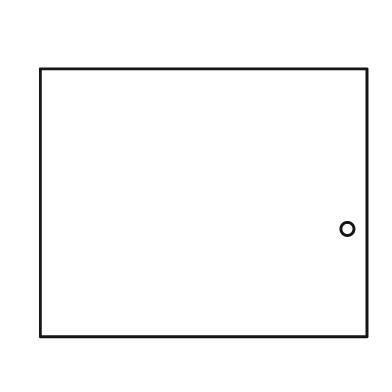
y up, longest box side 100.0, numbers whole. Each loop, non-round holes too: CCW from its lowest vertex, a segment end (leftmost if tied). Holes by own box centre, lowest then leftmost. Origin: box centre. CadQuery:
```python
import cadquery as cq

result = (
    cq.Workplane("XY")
    .moveTo(-50.0, -41.0)
    .lineTo(50.0, -41.0)
    .lineTo(50.0, 41.0)
    .lineTo(-50.0, 41.0)
    .close()
    .moveTo(44.0, -8.0)
    .circle(2.0)
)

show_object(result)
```